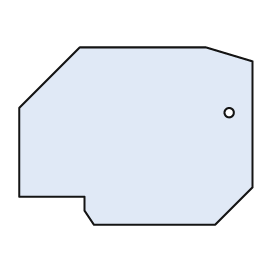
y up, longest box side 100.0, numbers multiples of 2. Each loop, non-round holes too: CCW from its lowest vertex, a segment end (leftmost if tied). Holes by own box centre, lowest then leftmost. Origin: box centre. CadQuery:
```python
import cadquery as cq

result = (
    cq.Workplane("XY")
    .moveTo(-18.0, -38.0)
    .lineTo(34.0, -38.0)
    .lineTo(50.0, -22.0)
    .lineTo(50.0, 32.0)
    .lineTo(30.0, 38.0)
    .lineTo(-24.0, 38.0)
    .lineTo(-50.0, 12.0)
    .lineTo(-50.0, -26.0)
    .lineTo(-22.0, -26.0)
    .lineTo(-22.0, -32.0)
    .close()
    .moveTo(40.0, 10.0)
    .circle(2.0)
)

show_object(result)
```